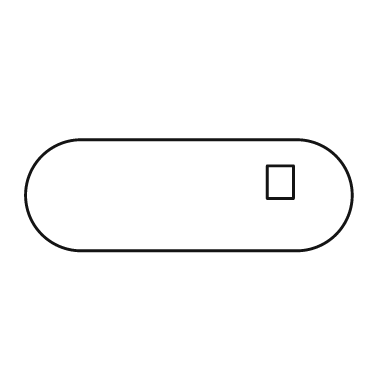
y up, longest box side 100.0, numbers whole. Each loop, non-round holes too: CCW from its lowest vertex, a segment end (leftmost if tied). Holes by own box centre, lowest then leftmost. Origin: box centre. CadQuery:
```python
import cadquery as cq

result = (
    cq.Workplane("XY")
    .moveTo(-33.0, -17.0)
    .lineTo(33.0, -17.0)
    .threePointArc((50.0, 0.0), (33.0, 17.0))
    .lineTo(-33.0, 17.0)
    .threePointArc((-50.0, 0.0), (-33.0, -17.0))
    .close()
    .moveTo(24.0, -1.0)
    .lineTo(32.0, -1.0)
    .lineTo(32.0, 9.0)
    .lineTo(24.0, 9.0)
    .close()
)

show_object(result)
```